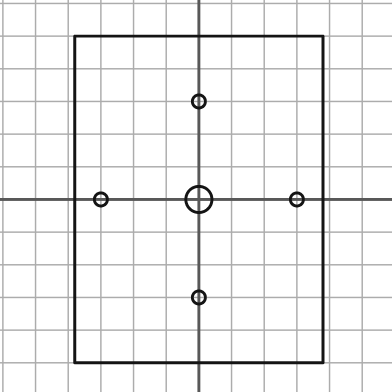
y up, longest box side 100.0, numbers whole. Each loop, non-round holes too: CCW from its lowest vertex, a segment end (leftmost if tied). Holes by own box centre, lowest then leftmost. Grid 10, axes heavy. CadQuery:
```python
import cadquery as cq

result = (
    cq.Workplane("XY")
    .moveTo(-38.0, -50.0)
    .lineTo(38.0, -50.0)
    .lineTo(38.0, 50.0)
    .lineTo(-38.0, 50.0)
    .close()
    .moveTo(0.0, -30.0)
    .circle(2.0)
    .moveTo(-30.0, 0.0)
    .circle(2.0)
    .moveTo(0.0, 0.0)
    .circle(4.0)
    .moveTo(30.0, 0.0)
    .circle(2.0)
    .moveTo(0.0, 30.0)
    .circle(2.0)
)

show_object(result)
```